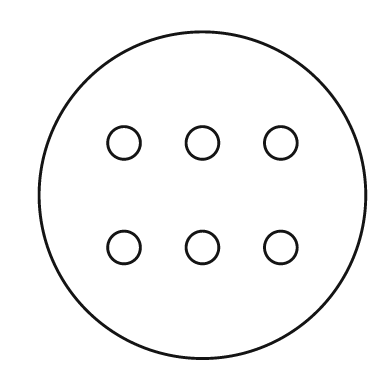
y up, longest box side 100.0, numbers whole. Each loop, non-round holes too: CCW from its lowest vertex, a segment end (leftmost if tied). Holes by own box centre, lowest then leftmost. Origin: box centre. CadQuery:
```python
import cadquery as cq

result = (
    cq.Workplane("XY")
    .moveTo(0.0, 0.0)
    .circle(50.0)
    .moveTo(-24.0, -16.0)
    .circle(5.0)
    .moveTo(0.0, -16.0)
    .circle(5.0)
    .moveTo(24.0, -16.0)
    .circle(5.0)
    .moveTo(-24.0, 16.0)
    .circle(5.0)
    .moveTo(0.0, 16.0)
    .circle(5.0)
    .moveTo(24.0, 16.0)
    .circle(5.0)
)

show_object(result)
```